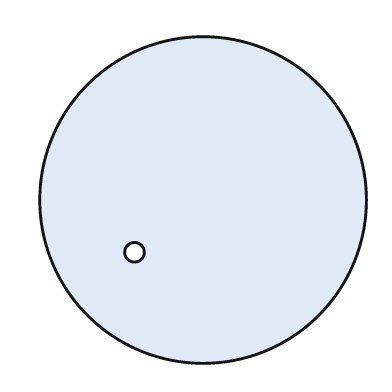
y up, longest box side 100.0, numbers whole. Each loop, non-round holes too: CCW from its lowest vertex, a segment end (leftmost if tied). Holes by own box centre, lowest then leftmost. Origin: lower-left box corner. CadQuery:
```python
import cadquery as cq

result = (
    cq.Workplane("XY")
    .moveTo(50.0, 50.0)
    .circle(50.0)
    .moveTo(29.0, 34.0)
    .circle(3.0)
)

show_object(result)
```